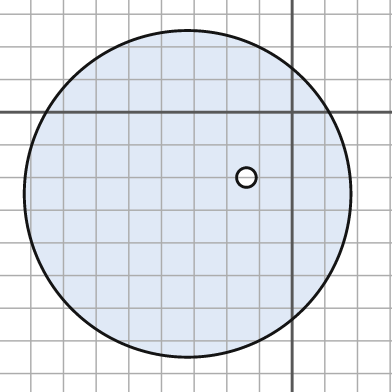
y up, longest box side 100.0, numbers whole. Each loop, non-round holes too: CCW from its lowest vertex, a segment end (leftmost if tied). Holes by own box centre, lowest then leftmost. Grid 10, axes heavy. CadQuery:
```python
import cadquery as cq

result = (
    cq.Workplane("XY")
    .moveTo(-32.0, -25.0)
    .circle(50.0)
    .moveTo(-14.0, -20.0)
    .circle(3.0)
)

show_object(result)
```